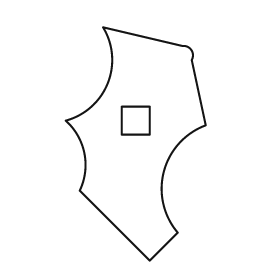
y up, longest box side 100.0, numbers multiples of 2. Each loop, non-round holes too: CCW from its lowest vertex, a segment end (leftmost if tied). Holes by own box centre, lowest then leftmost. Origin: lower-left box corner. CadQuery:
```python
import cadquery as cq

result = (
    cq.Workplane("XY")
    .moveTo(36.0, 0.0)
    .lineTo(48.0, 12.0)
    .threePointArc((42.0, 38.0), (60.0, 58.0))
    .lineTo(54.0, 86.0)
    .threePointArc((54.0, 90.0), (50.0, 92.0))
    .lineTo(16.0, 100.0)
    .threePointArc((18.0, 76.0), (0.0, 60.0))
    .threePointArc((8.0, 46.0), (6.0, 30.0))
    .close()
    .moveTo(24.0, 54.0)
    .lineTo(36.0, 54.0)
    .lineTo(36.0, 66.0)
    .lineTo(24.0, 66.0)
    .close()
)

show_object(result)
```